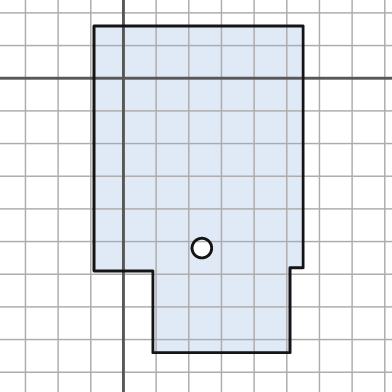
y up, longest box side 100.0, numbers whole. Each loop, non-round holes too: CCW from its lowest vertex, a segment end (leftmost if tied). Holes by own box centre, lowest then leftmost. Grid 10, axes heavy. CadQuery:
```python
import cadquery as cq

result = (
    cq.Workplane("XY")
    .moveTo(9.0, -84.0)
    .lineTo(51.0, -84.0)
    .lineTo(51.0, -58.0)
    .lineTo(55.0, -58.0)
    .lineTo(55.0, 16.0)
    .lineTo(-9.0, 16.0)
    .lineTo(-9.0, -59.0)
    .lineTo(9.0, -59.0)
    .close()
    .moveTo(24.0, -52.0)
    .circle(3.0)
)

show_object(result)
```